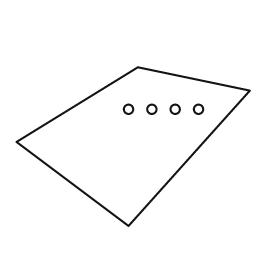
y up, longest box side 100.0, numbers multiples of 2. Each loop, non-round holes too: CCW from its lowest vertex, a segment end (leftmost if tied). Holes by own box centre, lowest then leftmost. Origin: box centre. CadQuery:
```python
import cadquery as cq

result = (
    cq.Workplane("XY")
    .moveTo(-2.0, -34.0)
    .lineTo(50.0, 24.0)
    .lineTo(2.0, 34.0)
    .lineTo(-50.0, 2.0)
    .close()
    .moveTo(-2.0, 16.0)
    .circle(2.0)
    .moveTo(8.0, 16.0)
    .circle(2.0)
    .moveTo(18.0, 16.0)
    .circle(2.0)
    .moveTo(28.0, 16.0)
    .circle(2.0)
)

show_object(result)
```